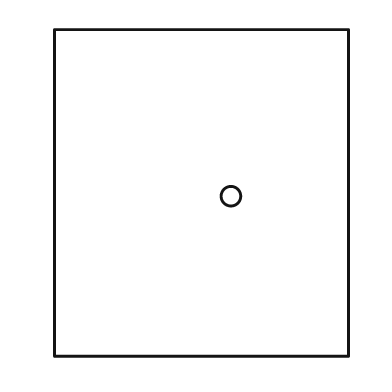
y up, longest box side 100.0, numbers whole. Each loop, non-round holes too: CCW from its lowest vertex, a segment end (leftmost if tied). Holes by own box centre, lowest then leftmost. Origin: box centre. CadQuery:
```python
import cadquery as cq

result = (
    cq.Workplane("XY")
    .moveTo(-45.0, -50.0)
    .lineTo(45.0, -50.0)
    .lineTo(45.0, 50.0)
    .lineTo(-45.0, 50.0)
    .close()
    .moveTo(9.0, -1.0)
    .circle(3.0)
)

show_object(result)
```